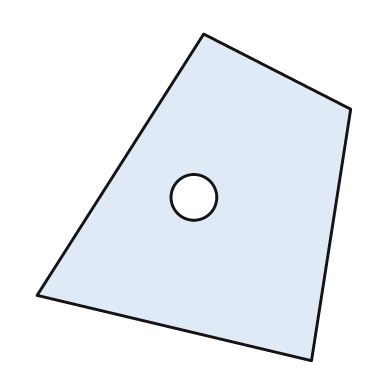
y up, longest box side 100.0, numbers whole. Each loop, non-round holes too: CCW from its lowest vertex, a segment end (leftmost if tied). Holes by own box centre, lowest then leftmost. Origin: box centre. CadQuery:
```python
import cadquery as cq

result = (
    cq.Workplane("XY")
    .moveTo(36.0, -50.0)
    .lineTo(48.0, 27.0)
    .lineTo(3.0, 50.0)
    .lineTo(-48.0, -30.0)
    .close()
    .moveTo(0.0, 0.0)
    .circle(7.0)
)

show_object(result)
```